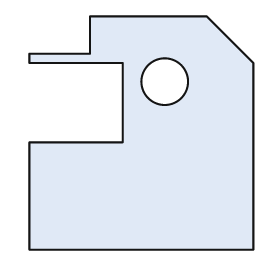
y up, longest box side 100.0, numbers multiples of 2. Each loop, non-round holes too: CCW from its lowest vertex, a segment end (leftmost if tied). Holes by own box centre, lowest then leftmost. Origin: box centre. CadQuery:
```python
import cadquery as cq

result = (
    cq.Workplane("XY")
    .moveTo(-48.0, -50.0)
    .lineTo(48.0, -50.0)
    .lineTo(48.0, 30.0)
    .lineTo(28.0, 50.0)
    .lineTo(-22.0, 50.0)
    .lineTo(-22.0, 34.0)
    .lineTo(-48.0, 34.0)
    .lineTo(-48.0, 30.0)
    .lineTo(-8.0, 30.0)
    .lineTo(-8.0, -4.0)
    .lineTo(-48.0, -4.0)
    .close()
    .moveTo(10.0, 22.0)
    .circle(10.0)
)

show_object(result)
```